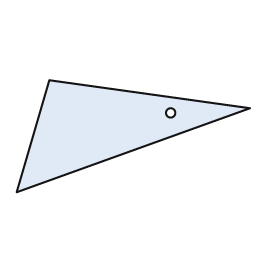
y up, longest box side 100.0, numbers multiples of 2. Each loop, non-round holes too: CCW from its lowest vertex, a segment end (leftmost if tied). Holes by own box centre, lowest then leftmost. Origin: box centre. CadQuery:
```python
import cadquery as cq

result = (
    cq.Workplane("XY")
    .moveTo(-50.0, -24.0)
    .lineTo(50.0, 12.0)
    .lineTo(-36.0, 24.0)
    .close()
    .moveTo(16.0, 10.0)
    .circle(2.0)
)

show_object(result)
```